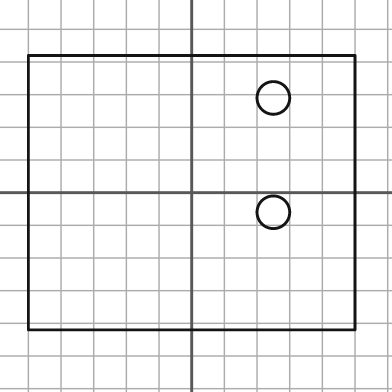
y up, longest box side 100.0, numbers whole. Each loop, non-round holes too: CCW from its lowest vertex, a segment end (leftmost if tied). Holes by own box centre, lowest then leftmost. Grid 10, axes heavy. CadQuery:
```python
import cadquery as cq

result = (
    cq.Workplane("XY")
    .moveTo(-50.0, -42.0)
    .lineTo(50.0, -42.0)
    .lineTo(50.0, 42.0)
    .lineTo(-50.0, 42.0)
    .close()
    .moveTo(25.0, -6.0)
    .circle(5.0)
    .moveTo(25.0, 29.0)
    .circle(5.0)
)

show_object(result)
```